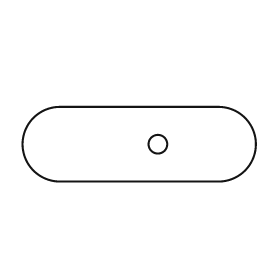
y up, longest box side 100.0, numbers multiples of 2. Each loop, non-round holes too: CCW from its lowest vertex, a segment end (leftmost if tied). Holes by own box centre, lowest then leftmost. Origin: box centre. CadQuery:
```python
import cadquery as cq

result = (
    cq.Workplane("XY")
    .moveTo(-34.0, -16.0)
    .lineTo(34.0, -16.0)
    .threePointArc((50.0, 0.0), (34.0, 16.0))
    .lineTo(-34.0, 16.0)
    .threePointArc((-50.0, 0.0), (-34.0, -16.0))
    .close()
    .moveTo(8.0, 0.0)
    .circle(4.0)
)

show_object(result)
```